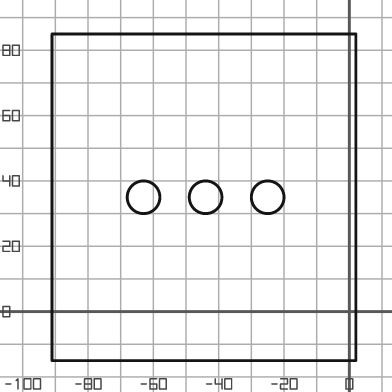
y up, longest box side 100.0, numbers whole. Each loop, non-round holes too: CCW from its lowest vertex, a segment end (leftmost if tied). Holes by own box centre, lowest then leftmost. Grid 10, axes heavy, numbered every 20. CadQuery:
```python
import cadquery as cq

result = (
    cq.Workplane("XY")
    .moveTo(-91.0, -15.0)
    .lineTo(2.0, -15.0)
    .lineTo(2.0, 85.0)
    .lineTo(-91.0, 85.0)
    .close()
    .moveTo(-63.0, 35.0)
    .circle(5.0)
    .moveTo(-44.0, 35.0)
    .circle(5.0)
    .moveTo(-25.0, 35.0)
    .circle(5.0)
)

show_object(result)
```